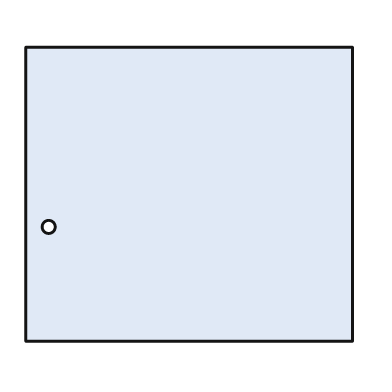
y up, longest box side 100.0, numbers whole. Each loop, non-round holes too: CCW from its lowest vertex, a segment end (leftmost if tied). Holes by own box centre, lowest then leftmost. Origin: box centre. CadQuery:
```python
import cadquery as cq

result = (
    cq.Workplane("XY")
    .moveTo(-50.0, -45.0)
    .lineTo(50.0, -45.0)
    .lineTo(50.0, 45.0)
    .lineTo(-50.0, 45.0)
    .close()
    .moveTo(-43.0, -10.0)
    .circle(2.0)
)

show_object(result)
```